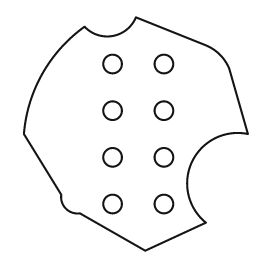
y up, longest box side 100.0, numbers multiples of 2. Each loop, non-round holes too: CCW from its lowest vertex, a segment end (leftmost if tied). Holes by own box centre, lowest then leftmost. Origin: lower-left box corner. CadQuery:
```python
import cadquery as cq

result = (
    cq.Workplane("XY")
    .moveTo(52.0, 0.0)
    .lineTo(78.0, 12.0)
    .threePointArc((72.0, 38.0), (96.0, 50.0))
    .lineTo(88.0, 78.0)
    .threePointArc((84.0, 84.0), (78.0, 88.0))
    .lineTo(48.0, 100.0)
    .threePointArc((38.0, 92.0), (26.0, 96.0))
    .threePointArc((8.0, 76.0), (0.0, 50.0))
    .lineTo(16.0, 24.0)
    .threePointArc((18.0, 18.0), (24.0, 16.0))
    .close()
    .moveTo(38.0, 20.0)
    .circle(4.0)
    .moveTo(60.0, 20.0)
    .circle(4.0)
    .moveTo(38.0, 40.0)
    .circle(4.0)
    .moveTo(60.0, 40.0)
    .circle(4.0)
    .moveTo(38.0, 60.0)
    .circle(4.0)
    .moveTo(60.0, 60.0)
    .circle(4.0)
    .moveTo(38.0, 80.0)
    .circle(4.0)
    .moveTo(60.0, 80.0)
    .circle(4.0)
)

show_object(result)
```